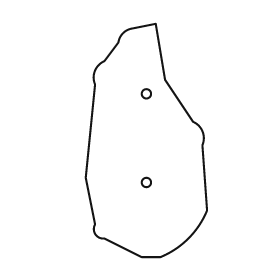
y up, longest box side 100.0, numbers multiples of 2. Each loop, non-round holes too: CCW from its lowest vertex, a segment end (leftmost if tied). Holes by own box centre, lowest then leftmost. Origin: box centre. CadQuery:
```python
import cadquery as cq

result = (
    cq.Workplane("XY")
    .moveTo(-2.0, -50.0)
    .lineTo(6.0, -50.0)
    .threePointArc((18.0, -42.0), (26.0, -30.0))
    .lineTo(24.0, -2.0)
    .threePointArc((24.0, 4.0), (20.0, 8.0))
    .lineTo(8.0, 26.0)
    .lineTo(4.0, 50.0)
    .lineTo(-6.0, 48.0)
    .threePointArc((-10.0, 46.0), (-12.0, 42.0))
    .lineTo(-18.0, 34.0)
    .threePointArc((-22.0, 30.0), (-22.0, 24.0))
    .lineTo(-26.0, -16.0)
    .lineTo(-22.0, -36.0)
    .threePointArc((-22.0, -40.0), (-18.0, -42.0))
    .close()
    .moveTo(0.0, -18.0)
    .circle(2.0)
    .moveTo(0.0, 20.0)
    .circle(2.0)
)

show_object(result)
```